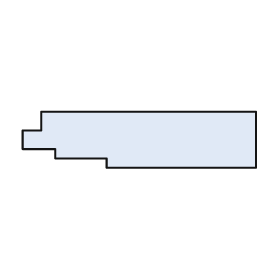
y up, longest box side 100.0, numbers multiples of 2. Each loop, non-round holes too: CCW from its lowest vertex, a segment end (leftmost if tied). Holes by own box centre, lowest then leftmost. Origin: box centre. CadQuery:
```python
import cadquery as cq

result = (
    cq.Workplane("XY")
    .moveTo(-14.0, -12.0)
    .lineTo(50.0, -12.0)
    .lineTo(50.0, 12.0)
    .lineTo(-42.0, 12.0)
    .lineTo(-42.0, 4.0)
    .lineTo(-50.0, 4.0)
    .lineTo(-50.0, -4.0)
    .lineTo(-36.0, -4.0)
    .lineTo(-36.0, -8.0)
    .lineTo(-14.0, -8.0)
    .close()
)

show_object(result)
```